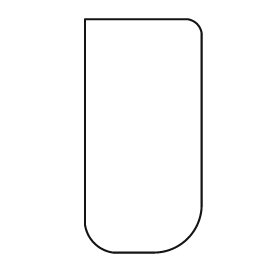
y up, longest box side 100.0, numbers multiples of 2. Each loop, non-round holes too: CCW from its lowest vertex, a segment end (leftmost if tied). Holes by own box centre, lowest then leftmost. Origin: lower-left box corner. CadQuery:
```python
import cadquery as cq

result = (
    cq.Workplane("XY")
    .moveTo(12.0, 0.0)
    .lineTo(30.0, 0.0)
    .threePointArc((44.0, 6.0), (50.0, 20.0))
    .lineTo(50.0, 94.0)
    .threePointArc((48.0, 98.0), (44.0, 100.0))
    .lineTo(0.0, 100.0)
    .lineTo(0.0, 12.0)
    .threePointArc((4.0, 4.0), (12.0, 0.0))
    .close()
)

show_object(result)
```